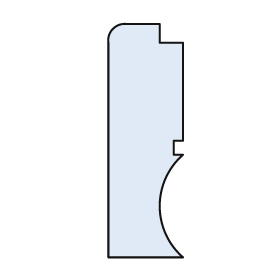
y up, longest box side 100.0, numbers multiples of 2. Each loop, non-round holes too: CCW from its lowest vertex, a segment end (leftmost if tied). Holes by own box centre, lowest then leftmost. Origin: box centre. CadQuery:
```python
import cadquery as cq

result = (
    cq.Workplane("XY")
    .moveTo(-16.0, -50.0)
    .lineTo(16.0, -50.0)
    .threePointArc((6.0, -28.0), (16.0, -6.0))
    .lineTo(12.0, -6.0)
    .lineTo(12.0, 0.0)
    .lineTo(16.0, 0.0)
    .lineTo(16.0, 42.0)
    .lineTo(6.0, 42.0)
    .lineTo(6.0, 50.0)
    .lineTo(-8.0, 50.0)
    .threePointArc((-14.0, 48.0), (-16.0, 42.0))
    .close()
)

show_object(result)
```